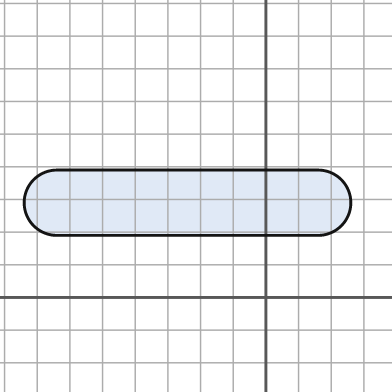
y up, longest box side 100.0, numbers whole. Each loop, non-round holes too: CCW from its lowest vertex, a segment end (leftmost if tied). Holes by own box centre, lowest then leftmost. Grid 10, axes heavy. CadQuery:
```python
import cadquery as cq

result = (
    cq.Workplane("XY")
    .moveTo(-64.0, 19.0)
    .lineTo(16.0, 19.0)
    .threePointArc((26.0, 29.0), (16.0, 39.0))
    .lineTo(-64.0, 39.0)
    .threePointArc((-74.0, 29.0), (-64.0, 19.0))
    .close()
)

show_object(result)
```